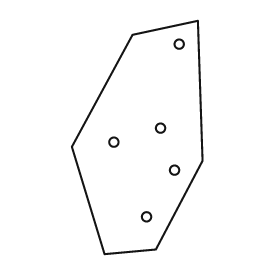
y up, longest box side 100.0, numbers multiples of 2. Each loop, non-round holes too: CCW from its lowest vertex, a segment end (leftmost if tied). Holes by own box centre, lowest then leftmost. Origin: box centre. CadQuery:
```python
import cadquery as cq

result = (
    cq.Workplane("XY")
    .moveTo(-14.0, -50.0)
    .lineTo(8.0, -48.0)
    .lineTo(28.0, -10.0)
    .lineTo(26.0, 50.0)
    .lineTo(-2.0, 44.0)
    .lineTo(-28.0, -4.0)
    .close()
    .moveTo(4.0, -34.0)
    .circle(2.0)
    .moveTo(16.0, -14.0)
    .circle(2.0)
    .moveTo(-10.0, -2.0)
    .circle(2.0)
    .moveTo(10.0, 4.0)
    .circle(2.0)
    .moveTo(18.0, 40.0)
    .circle(2.0)
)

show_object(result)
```